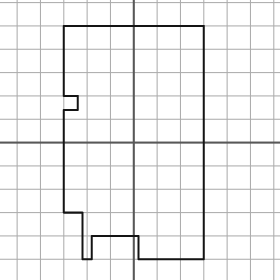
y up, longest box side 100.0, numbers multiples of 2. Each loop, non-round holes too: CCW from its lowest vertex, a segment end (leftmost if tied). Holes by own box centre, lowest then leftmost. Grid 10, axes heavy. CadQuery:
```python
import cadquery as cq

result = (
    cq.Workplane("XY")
    .moveTo(-22.0, -50.0)
    .lineTo(-18.0, -50.0)
    .lineTo(-18.0, -40.0)
    .lineTo(2.0, -40.0)
    .lineTo(2.0, -50.0)
    .lineTo(30.0, -50.0)
    .lineTo(30.0, 50.0)
    .lineTo(-30.0, 50.0)
    .lineTo(-30.0, 20.0)
    .lineTo(-24.0, 20.0)
    .lineTo(-24.0, 14.0)
    .lineTo(-30.0, 14.0)
    .lineTo(-30.0, -30.0)
    .lineTo(-22.0, -30.0)
    .close()
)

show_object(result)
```